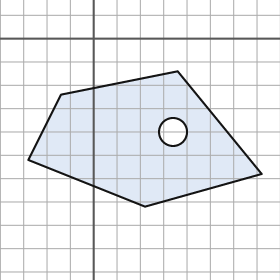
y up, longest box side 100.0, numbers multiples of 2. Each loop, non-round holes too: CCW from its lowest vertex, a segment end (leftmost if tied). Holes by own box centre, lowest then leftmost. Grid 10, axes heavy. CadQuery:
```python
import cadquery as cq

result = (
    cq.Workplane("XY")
    .moveTo(22.0, -72.0)
    .lineTo(72.0, -58.0)
    .lineTo(36.0, -14.0)
    .lineTo(-14.0, -24.0)
    .lineTo(-28.0, -52.0)
    .close()
    .moveTo(34.0, -40.0)
    .circle(6.0)
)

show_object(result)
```